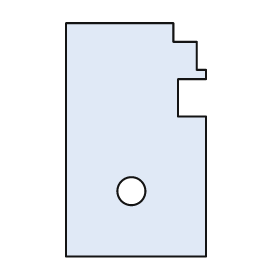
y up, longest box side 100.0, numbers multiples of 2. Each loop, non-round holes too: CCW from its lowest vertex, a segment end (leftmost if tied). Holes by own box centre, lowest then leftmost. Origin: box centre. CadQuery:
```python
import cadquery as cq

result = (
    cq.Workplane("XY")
    .moveTo(-30.0, -50.0)
    .lineTo(30.0, -50.0)
    .lineTo(30.0, 10.0)
    .lineTo(18.0, 10.0)
    .lineTo(18.0, 26.0)
    .lineTo(30.0, 26.0)
    .lineTo(30.0, 30.0)
    .lineTo(26.0, 30.0)
    .lineTo(26.0, 42.0)
    .lineTo(16.0, 42.0)
    .lineTo(16.0, 50.0)
    .lineTo(-30.0, 50.0)
    .close()
    .moveTo(-2.0, -22.0)
    .circle(6.0)
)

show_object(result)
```